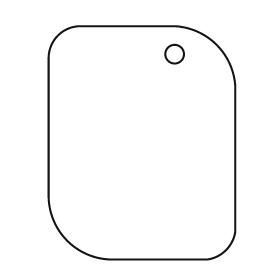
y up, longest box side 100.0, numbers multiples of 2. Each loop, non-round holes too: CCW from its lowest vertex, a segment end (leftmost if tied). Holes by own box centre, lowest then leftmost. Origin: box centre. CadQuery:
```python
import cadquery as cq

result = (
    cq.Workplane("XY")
    .moveTo(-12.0, -50.0)
    .lineTo(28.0, -50.0)
    .threePointArc((36.0, -46.0), (40.0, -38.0))
    .lineTo(40.0, 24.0)
    .threePointArc((32.0, 42.0), (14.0, 50.0))
    .lineTo(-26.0, 50.0)
    .threePointArc((-36.0, 46.0), (-40.0, 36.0))
    .lineTo(-40.0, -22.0)
    .threePointArc((-32.0, -42.0), (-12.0, -50.0))
    .close()
    .moveTo(14.0, 38.0)
    .circle(4.0)
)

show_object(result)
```